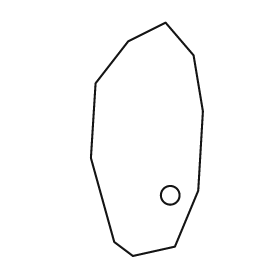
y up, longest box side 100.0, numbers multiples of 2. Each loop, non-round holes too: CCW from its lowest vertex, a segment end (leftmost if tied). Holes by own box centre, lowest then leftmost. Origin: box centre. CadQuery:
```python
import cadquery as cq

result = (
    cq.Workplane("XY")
    .moveTo(-6.0, -50.0)
    .lineTo(12.0, -46.0)
    .lineTo(22.0, -22.0)
    .lineTo(24.0, 12.0)
    .lineTo(20.0, 36.0)
    .lineTo(8.0, 50.0)
    .lineTo(-8.0, 42.0)
    .lineTo(-22.0, 24.0)
    .lineTo(-24.0, -8.0)
    .lineTo(-14.0, -44.0)
    .close()
    .moveTo(10.0, -24.0)
    .circle(4.0)
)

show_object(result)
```